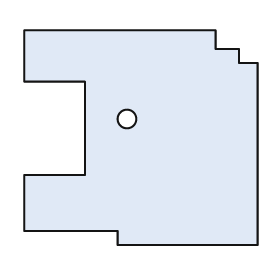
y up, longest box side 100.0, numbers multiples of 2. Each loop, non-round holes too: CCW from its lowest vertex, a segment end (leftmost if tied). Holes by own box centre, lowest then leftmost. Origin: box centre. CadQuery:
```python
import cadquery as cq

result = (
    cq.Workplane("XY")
    .moveTo(-10.0, -46.0)
    .lineTo(50.0, -46.0)
    .lineTo(50.0, 32.0)
    .lineTo(42.0, 32.0)
    .lineTo(42.0, 38.0)
    .lineTo(32.0, 38.0)
    .lineTo(32.0, 46.0)
    .lineTo(-50.0, 46.0)
    .lineTo(-50.0, 24.0)
    .lineTo(-24.0, 24.0)
    .lineTo(-24.0, -16.0)
    .lineTo(-50.0, -16.0)
    .lineTo(-50.0, -40.0)
    .lineTo(-10.0, -40.0)
    .close()
    .moveTo(-6.0, 8.0)
    .circle(4.0)
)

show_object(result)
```